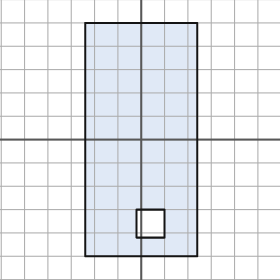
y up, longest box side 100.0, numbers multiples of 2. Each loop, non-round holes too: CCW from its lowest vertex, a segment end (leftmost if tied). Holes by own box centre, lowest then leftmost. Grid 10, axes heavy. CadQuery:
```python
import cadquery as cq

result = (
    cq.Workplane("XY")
    .moveTo(-24.0, -50.0)
    .lineTo(24.0, -50.0)
    .lineTo(24.0, 50.0)
    .lineTo(-24.0, 50.0)
    .close()
    .moveTo(-2.0, -42.0)
    .lineTo(10.0, -42.0)
    .lineTo(10.0, -30.0)
    .lineTo(-2.0, -30.0)
    .close()
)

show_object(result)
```